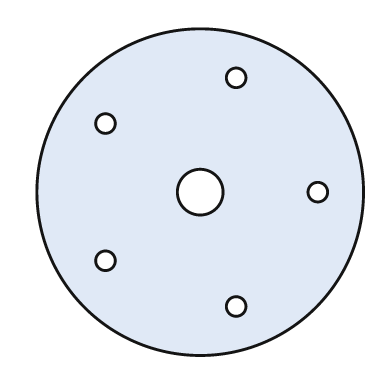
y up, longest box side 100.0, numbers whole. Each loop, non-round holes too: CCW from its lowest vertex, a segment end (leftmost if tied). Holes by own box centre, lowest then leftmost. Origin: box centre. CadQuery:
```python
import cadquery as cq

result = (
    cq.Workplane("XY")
    .moveTo(0.0, 0.0)
    .circle(50.0)
    .moveTo(11.0, -35.0)
    .circle(3.0)
    .moveTo(-29.0, -21.0)
    .circle(3.0)
    .moveTo(0.0, 0.0)
    .circle(7.0)
    .moveTo(36.0, 0.0)
    .circle(3.0)
    .moveTo(-29.0, 21.0)
    .circle(3.0)
    .moveTo(11.0, 35.0)
    .circle(3.0)
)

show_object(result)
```